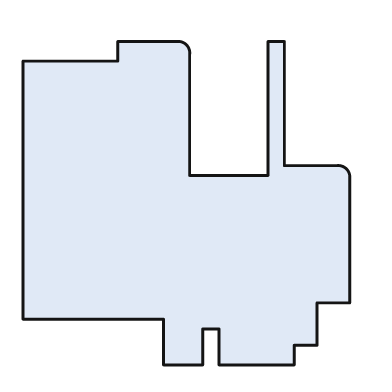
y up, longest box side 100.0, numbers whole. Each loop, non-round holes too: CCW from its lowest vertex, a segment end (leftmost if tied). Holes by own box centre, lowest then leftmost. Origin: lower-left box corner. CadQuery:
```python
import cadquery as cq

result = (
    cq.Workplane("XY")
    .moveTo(43.0, 0.0)
    .lineTo(55.0, 0.0)
    .lineTo(55.0, 11.0)
    .lineTo(60.0, 11.0)
    .lineTo(60.0, 0.0)
    .lineTo(83.0, 0.0)
    .lineTo(83.0, 6.0)
    .lineTo(90.0, 6.0)
    .lineTo(90.0, 19.0)
    .lineTo(100.0, 19.0)
    .lineTo(100.0, 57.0)
    .threePointArc((99.0, 60.0), (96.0, 61.0))
    .lineTo(80.0, 61.0)
    .lineTo(80.0, 99.0)
    .lineTo(75.0, 99.0)
    .lineTo(75.0, 58.0)
    .lineTo(51.0, 58.0)
    .lineTo(51.0, 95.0)
    .threePointArc((50.0, 98.0), (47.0, 99.0))
    .lineTo(29.0, 99.0)
    .lineTo(29.0, 93.0)
    .lineTo(0.0, 93.0)
    .lineTo(0.0, 14.0)
    .lineTo(43.0, 14.0)
    .close()
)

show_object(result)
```